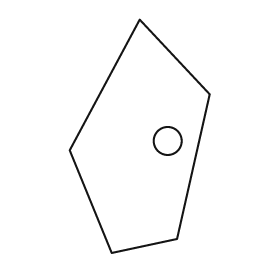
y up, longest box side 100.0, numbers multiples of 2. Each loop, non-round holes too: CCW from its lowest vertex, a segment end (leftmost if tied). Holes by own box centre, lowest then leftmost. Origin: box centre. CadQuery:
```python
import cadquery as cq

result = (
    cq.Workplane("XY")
    .moveTo(-12.0, -50.0)
    .lineTo(16.0, -44.0)
    .lineTo(30.0, 18.0)
    .lineTo(0.0, 50.0)
    .lineTo(-30.0, -6.0)
    .close()
    .moveTo(12.0, -2.0)
    .circle(6.0)
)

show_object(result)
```